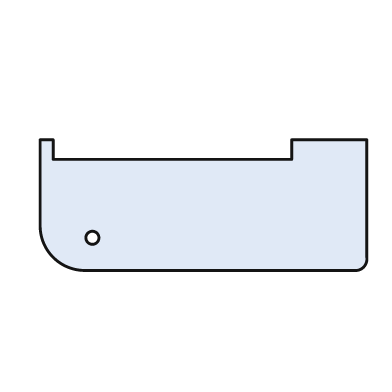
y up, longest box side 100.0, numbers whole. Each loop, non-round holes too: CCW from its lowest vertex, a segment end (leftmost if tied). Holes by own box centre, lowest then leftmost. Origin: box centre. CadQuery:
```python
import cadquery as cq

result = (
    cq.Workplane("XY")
    .moveTo(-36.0, -20.0)
    .lineTo(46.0, -20.0)
    .threePointArc((49.0, -19.0), (50.0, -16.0))
    .lineTo(50.0, 20.0)
    .lineTo(27.0, 20.0)
    .lineTo(27.0, 14.0)
    .lineTo(-46.0, 14.0)
    .lineTo(-46.0, 20.0)
    .lineTo(-50.0, 20.0)
    .lineTo(-50.0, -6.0)
    .threePointArc((-46.0, -16.0), (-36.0, -20.0))
    .close()
    .moveTo(-34.0, -10.0)
    .circle(2.0)
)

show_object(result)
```